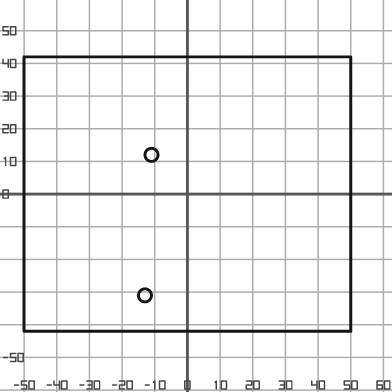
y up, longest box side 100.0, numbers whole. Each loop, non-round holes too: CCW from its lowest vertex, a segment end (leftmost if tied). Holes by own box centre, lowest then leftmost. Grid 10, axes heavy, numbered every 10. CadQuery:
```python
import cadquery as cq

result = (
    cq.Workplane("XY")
    .moveTo(-50.0, -42.0)
    .lineTo(50.0, -42.0)
    .lineTo(50.0, 42.0)
    .lineTo(-50.0, 42.0)
    .close()
    .moveTo(-13.0, -31.0)
    .circle(2.0)
    .moveTo(-11.0, 12.0)
    .circle(2.0)
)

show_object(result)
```